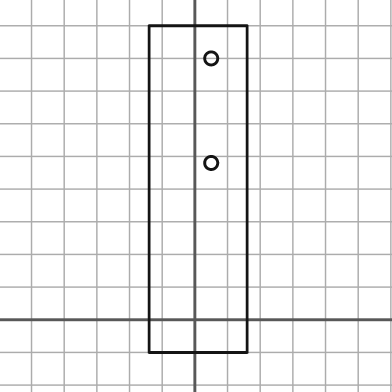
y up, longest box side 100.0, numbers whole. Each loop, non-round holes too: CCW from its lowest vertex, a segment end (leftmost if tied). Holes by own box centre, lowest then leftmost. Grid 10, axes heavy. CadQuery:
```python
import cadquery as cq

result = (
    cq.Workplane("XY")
    .moveTo(-14.0, -10.0)
    .lineTo(16.0, -10.0)
    .lineTo(16.0, 90.0)
    .lineTo(-14.0, 90.0)
    .close()
    .moveTo(5.0, 48.0)
    .circle(2.0)
    .moveTo(5.0, 80.0)
    .circle(2.0)
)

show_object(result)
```